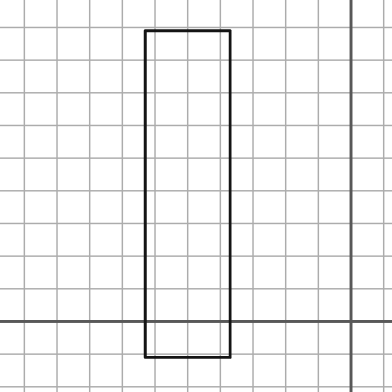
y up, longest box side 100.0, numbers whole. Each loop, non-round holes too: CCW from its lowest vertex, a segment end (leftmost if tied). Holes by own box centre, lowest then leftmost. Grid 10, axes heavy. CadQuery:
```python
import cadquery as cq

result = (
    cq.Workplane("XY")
    .moveTo(-63.0, -11.0)
    .lineTo(-37.0, -11.0)
    .lineTo(-37.0, 89.0)
    .lineTo(-63.0, 89.0)
    .close()
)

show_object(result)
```